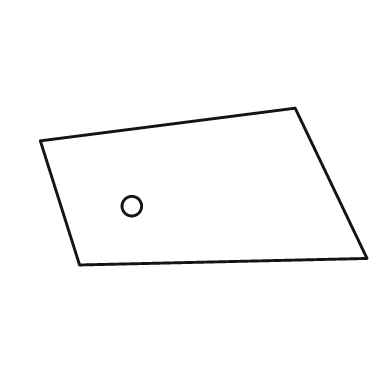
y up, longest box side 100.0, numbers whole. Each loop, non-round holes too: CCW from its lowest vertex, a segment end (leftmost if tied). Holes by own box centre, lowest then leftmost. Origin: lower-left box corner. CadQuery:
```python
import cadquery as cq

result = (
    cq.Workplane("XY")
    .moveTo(12.0, 0.0)
    .lineTo(100.0, 2.0)
    .lineTo(78.0, 48.0)
    .lineTo(0.0, 38.0)
    .close()
    .moveTo(28.0, 18.0)
    .circle(3.0)
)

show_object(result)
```